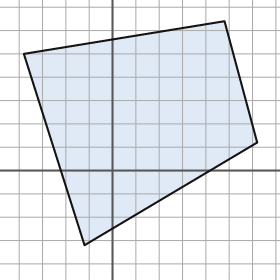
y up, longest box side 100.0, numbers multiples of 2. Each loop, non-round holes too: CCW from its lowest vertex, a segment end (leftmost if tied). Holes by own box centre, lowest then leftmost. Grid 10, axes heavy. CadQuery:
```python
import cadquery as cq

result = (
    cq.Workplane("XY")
    .moveTo(-12.0, -32.0)
    .lineTo(62.0, 12.0)
    .lineTo(48.0, 64.0)
    .lineTo(-38.0, 50.0)
    .close()
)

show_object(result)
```